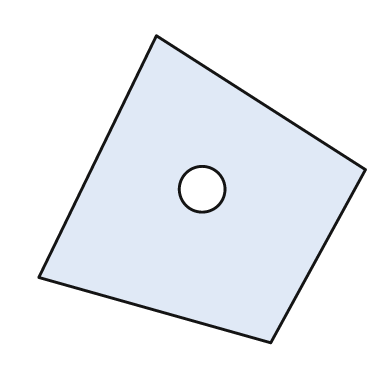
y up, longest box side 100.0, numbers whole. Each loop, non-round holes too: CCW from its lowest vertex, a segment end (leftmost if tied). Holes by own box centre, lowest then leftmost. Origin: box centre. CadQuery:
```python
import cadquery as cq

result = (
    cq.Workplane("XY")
    .moveTo(21.0, -47.0)
    .lineTo(50.0, 6.0)
    .lineTo(-14.0, 47.0)
    .lineTo(-50.0, -27.0)
    .close()
    .moveTo(0.0, 0.0)
    .circle(7.0)
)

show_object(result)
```